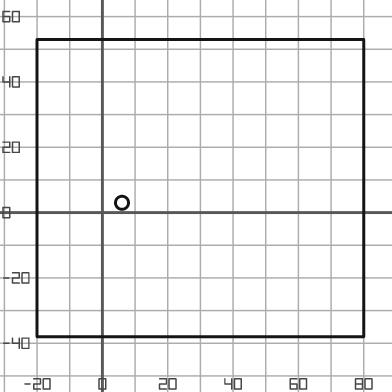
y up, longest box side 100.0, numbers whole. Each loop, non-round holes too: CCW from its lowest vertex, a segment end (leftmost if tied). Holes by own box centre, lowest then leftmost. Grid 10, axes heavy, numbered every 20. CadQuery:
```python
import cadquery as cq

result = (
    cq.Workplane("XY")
    .moveTo(-20.0, -38.0)
    .lineTo(80.0, -38.0)
    .lineTo(80.0, 53.0)
    .lineTo(-20.0, 53.0)
    .close()
    .moveTo(6.0, 3.0)
    .circle(2.0)
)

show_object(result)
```